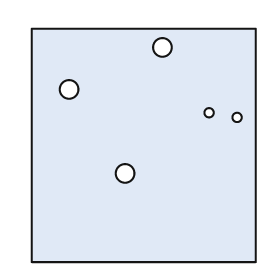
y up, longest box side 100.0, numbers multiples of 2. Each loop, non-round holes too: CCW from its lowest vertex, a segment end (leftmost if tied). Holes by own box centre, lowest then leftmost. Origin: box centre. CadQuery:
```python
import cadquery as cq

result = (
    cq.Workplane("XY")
    .moveTo(-48.0, -50.0)
    .lineTo(48.0, -50.0)
    .lineTo(48.0, 50.0)
    .lineTo(-48.0, 50.0)
    .close()
    .moveTo(-8.0, -12.0)
    .circle(4.0)
    .moveTo(40.0, 12.0)
    .circle(2.0)
    .moveTo(28.0, 14.0)
    .circle(2.0)
    .moveTo(-32.0, 24.0)
    .circle(4.0)
    .moveTo(8.0, 42.0)
    .circle(4.0)
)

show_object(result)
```